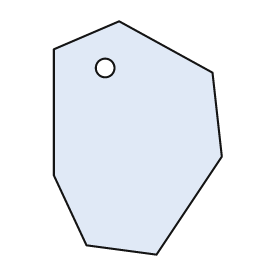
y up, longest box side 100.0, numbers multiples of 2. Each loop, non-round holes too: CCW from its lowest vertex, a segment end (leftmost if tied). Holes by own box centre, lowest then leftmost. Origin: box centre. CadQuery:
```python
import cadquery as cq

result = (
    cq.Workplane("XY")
    .moveTo(8.0, -50.0)
    .lineTo(36.0, -8.0)
    .lineTo(32.0, 28.0)
    .lineTo(-8.0, 50.0)
    .lineTo(-36.0, 38.0)
    .lineTo(-36.0, -16.0)
    .lineTo(-22.0, -46.0)
    .close()
    .moveTo(-14.0, 30.0)
    .circle(4.0)
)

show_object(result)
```